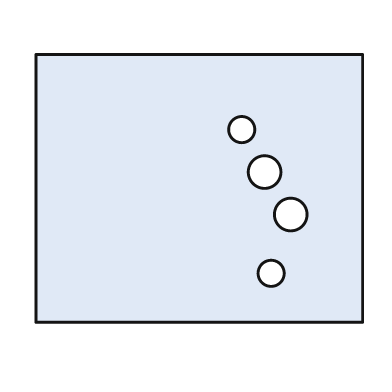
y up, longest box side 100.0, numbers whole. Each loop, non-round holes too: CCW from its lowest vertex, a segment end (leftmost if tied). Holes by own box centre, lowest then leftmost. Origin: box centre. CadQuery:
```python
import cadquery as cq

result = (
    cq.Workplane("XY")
    .moveTo(-50.0, -41.0)
    .lineTo(50.0, -41.0)
    .lineTo(50.0, 41.0)
    .lineTo(-50.0, 41.0)
    .close()
    .moveTo(22.0, -26.0)
    .circle(4.0)
    .moveTo(28.0, -8.0)
    .circle(5.0)
    .moveTo(20.0, 5.0)
    .circle(5.0)
    .moveTo(13.0, 18.0)
    .circle(4.0)
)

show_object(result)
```